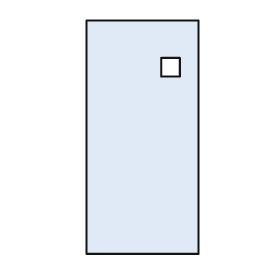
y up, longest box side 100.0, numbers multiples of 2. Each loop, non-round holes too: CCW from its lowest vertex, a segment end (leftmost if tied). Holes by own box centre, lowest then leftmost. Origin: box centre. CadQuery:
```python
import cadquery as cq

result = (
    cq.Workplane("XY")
    .moveTo(-24.0, -50.0)
    .lineTo(24.0, -50.0)
    .lineTo(24.0, 50.0)
    .lineTo(-24.0, 50.0)
    .close()
    .moveTo(8.0, 26.0)
    .lineTo(16.0, 26.0)
    .lineTo(16.0, 34.0)
    .lineTo(8.0, 34.0)
    .close()
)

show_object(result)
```